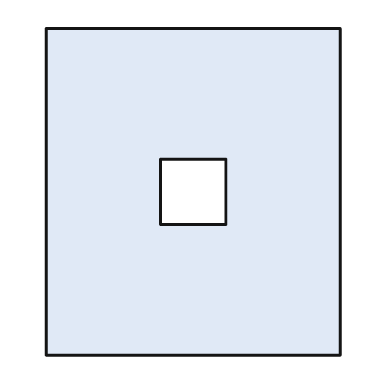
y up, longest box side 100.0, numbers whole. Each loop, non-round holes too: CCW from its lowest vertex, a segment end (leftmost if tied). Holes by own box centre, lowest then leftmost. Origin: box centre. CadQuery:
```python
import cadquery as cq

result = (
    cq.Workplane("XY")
    .moveTo(-45.0, -50.0)
    .lineTo(45.0, -50.0)
    .lineTo(45.0, 50.0)
    .lineTo(-45.0, 50.0)
    .close()
    .moveTo(-10.0, -10.0)
    .lineTo(10.0, -10.0)
    .lineTo(10.0, 10.0)
    .lineTo(-10.0, 10.0)
    .close()
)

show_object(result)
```